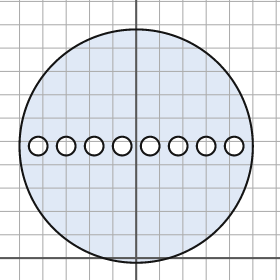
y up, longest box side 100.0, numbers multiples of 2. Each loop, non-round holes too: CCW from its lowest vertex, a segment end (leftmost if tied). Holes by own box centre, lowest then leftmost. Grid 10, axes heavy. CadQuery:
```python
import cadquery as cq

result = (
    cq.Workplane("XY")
    .moveTo(0.0, 48.0)
    .circle(50.0)
    .moveTo(-42.0, 48.0)
    .circle(4.0)
    .moveTo(-30.0, 48.0)
    .circle(4.0)
    .moveTo(-18.0, 48.0)
    .circle(4.0)
    .moveTo(-6.0, 48.0)
    .circle(4.0)
    .moveTo(6.0, 48.0)
    .circle(4.0)
    .moveTo(18.0, 48.0)
    .circle(4.0)
    .moveTo(30.0, 48.0)
    .circle(4.0)
    .moveTo(42.0, 48.0)
    .circle(4.0)
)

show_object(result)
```